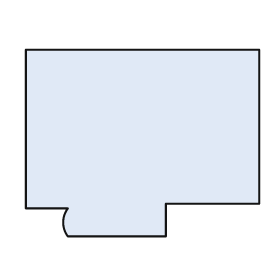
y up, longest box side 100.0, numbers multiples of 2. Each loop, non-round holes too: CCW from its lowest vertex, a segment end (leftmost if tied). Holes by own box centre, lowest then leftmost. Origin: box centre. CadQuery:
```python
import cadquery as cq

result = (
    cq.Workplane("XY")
    .moveTo(-32.0, -40.0)
    .lineTo(10.0, -40.0)
    .lineTo(10.0, -26.0)
    .lineTo(50.0, -26.0)
    .lineTo(50.0, 40.0)
    .lineTo(-50.0, 40.0)
    .lineTo(-50.0, -28.0)
    .lineTo(-32.0, -28.0)
    .threePointArc((-34.0, -34.0), (-32.0, -40.0))
    .close()
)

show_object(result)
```